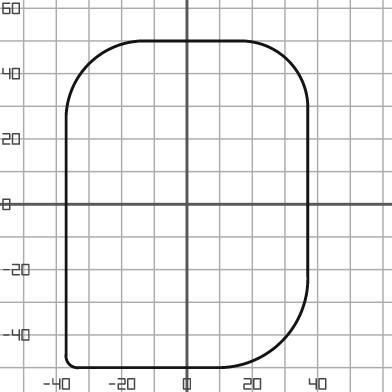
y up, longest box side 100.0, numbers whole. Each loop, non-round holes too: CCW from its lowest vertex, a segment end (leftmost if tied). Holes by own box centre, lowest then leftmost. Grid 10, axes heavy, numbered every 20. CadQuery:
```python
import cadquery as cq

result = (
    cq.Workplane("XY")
    .moveTo(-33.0, -50.0)
    .lineTo(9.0, -50.0)
    .threePointArc((29.0, -42.0), (37.0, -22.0))
    .lineTo(37.0, 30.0)
    .threePointArc((31.0, 44.0), (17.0, 50.0))
    .lineTo(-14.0, 50.0)
    .threePointArc((-30.0, 43.0), (-37.0, 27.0))
    .lineTo(-37.0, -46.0)
    .threePointArc((-36.0, -49.0), (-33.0, -50.0))
    .close()
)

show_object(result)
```